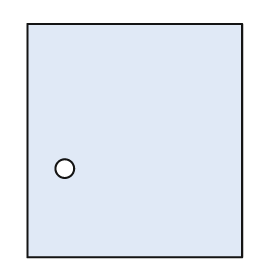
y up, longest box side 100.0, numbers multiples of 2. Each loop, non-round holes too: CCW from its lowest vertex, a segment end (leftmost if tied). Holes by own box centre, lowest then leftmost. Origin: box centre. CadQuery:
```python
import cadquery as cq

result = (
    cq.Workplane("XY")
    .moveTo(-46.0, -50.0)
    .lineTo(46.0, -50.0)
    .lineTo(46.0, 50.0)
    .lineTo(-46.0, 50.0)
    .close()
    .moveTo(-30.0, -12.0)
    .circle(4.0)
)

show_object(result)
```